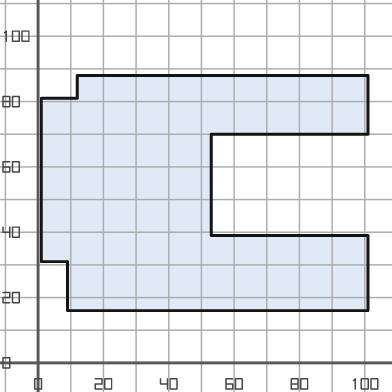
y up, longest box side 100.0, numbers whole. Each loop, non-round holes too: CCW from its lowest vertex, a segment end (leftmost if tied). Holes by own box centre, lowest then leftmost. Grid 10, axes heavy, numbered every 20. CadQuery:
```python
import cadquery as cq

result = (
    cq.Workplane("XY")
    .moveTo(9.0, 16.0)
    .lineTo(101.0, 16.0)
    .lineTo(101.0, 39.0)
    .lineTo(53.0, 39.0)
    .lineTo(53.0, 70.0)
    .lineTo(101.0, 70.0)
    .lineTo(101.0, 88.0)
    .lineTo(12.0, 88.0)
    .lineTo(12.0, 81.0)
    .lineTo(1.0, 81.0)
    .lineTo(1.0, 31.0)
    .lineTo(9.0, 31.0)
    .close()
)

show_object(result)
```